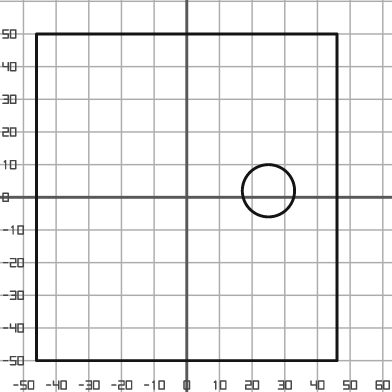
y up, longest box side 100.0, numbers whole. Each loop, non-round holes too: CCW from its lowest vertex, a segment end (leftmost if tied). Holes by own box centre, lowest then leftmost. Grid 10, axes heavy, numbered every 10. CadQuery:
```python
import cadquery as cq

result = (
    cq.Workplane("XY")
    .moveTo(-46.0, -50.0)
    .lineTo(46.0, -50.0)
    .lineTo(46.0, 50.0)
    .lineTo(-46.0, 50.0)
    .close()
    .moveTo(25.0, 2.0)
    .circle(8.0)
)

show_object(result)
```